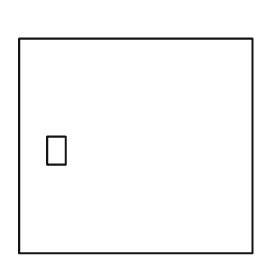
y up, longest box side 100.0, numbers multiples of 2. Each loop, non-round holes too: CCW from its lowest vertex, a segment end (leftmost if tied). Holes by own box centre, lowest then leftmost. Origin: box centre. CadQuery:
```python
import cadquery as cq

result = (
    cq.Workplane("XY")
    .moveTo(-50.0, -46.0)
    .lineTo(50.0, -46.0)
    .lineTo(50.0, 46.0)
    .lineTo(-50.0, 46.0)
    .close()
    .moveTo(-38.0, -8.0)
    .lineTo(-30.0, -8.0)
    .lineTo(-30.0, 4.0)
    .lineTo(-38.0, 4.0)
    .close()
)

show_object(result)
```